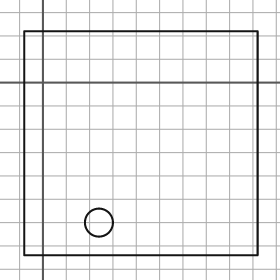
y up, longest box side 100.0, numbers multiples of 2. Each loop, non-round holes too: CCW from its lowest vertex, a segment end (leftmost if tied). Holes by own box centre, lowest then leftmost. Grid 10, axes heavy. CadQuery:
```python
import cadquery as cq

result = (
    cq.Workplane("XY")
    .moveTo(-8.0, -74.0)
    .lineTo(92.0, -74.0)
    .lineTo(92.0, 22.0)
    .lineTo(-8.0, 22.0)
    .close()
    .moveTo(24.0, -60.0)
    .circle(6.0)
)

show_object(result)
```